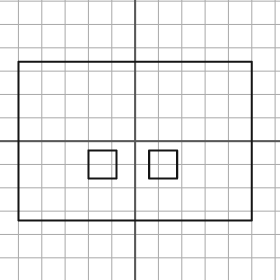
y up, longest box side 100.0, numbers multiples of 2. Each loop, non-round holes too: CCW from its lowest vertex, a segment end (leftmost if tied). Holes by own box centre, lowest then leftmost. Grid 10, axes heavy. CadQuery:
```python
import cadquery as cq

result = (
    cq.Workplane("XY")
    .moveTo(-50.0, -34.0)
    .lineTo(50.0, -34.0)
    .lineTo(50.0, 34.0)
    .lineTo(-50.0, 34.0)
    .close()
    .moveTo(-20.0, -16.0)
    .lineTo(-8.0, -16.0)
    .lineTo(-8.0, -4.0)
    .lineTo(-20.0, -4.0)
    .close()
    .moveTo(6.0, -16.0)
    .lineTo(18.0, -16.0)
    .lineTo(18.0, -4.0)
    .lineTo(6.0, -4.0)
    .close()
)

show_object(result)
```